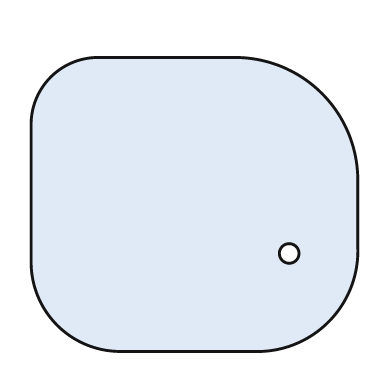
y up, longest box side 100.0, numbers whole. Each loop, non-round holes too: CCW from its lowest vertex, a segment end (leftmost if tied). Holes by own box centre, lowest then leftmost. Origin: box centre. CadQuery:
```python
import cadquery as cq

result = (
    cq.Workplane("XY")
    .moveTo(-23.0, -45.0)
    .lineTo(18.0, -45.0)
    .threePointArc((41.0, -36.0), (50.0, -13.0))
    .lineTo(50.0, 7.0)
    .threePointArc((39.0, 34.0), (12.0, 45.0))
    .lineTo(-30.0, 45.0)
    .threePointArc((-44.0, 39.0), (-50.0, 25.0))
    .lineTo(-50.0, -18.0)
    .threePointArc((-42.0, -37.0), (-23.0, -45.0))
    .close()
    .moveTo(29.0, -15.0)
    .circle(3.0)
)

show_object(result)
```